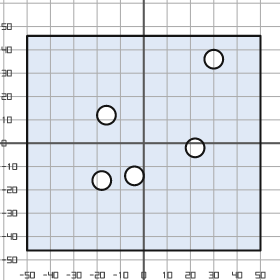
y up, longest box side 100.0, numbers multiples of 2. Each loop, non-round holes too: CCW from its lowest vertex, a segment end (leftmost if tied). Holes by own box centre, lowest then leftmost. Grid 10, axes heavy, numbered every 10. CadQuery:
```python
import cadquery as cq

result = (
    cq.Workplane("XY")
    .moveTo(-50.0, -46.0)
    .lineTo(50.0, -46.0)
    .lineTo(50.0, 46.0)
    .lineTo(-50.0, 46.0)
    .close()
    .moveTo(-18.0, -16.0)
    .circle(4.0)
    .moveTo(-4.0, -14.0)
    .circle(4.0)
    .moveTo(22.0, -2.0)
    .circle(4.0)
    .moveTo(-16.0, 12.0)
    .circle(4.0)
    .moveTo(30.0, 36.0)
    .circle(4.0)
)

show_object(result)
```